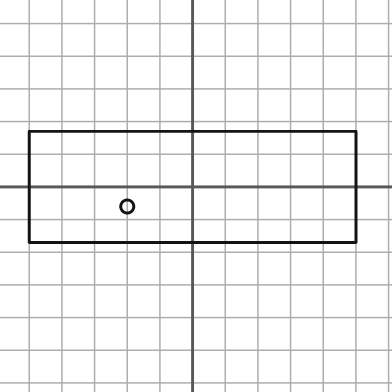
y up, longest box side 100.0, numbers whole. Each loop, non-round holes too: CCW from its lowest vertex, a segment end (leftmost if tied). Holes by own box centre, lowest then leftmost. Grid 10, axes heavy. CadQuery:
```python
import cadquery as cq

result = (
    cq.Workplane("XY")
    .moveTo(-50.0, -17.0)
    .lineTo(50.0, -17.0)
    .lineTo(50.0, 17.0)
    .lineTo(-50.0, 17.0)
    .close()
    .moveTo(-20.0, -6.0)
    .circle(2.0)
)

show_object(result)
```